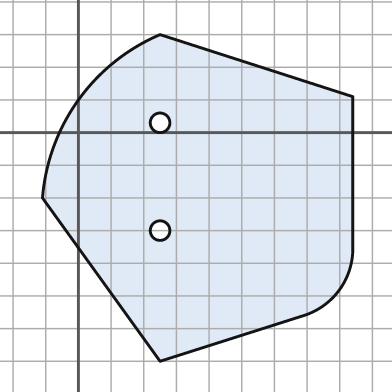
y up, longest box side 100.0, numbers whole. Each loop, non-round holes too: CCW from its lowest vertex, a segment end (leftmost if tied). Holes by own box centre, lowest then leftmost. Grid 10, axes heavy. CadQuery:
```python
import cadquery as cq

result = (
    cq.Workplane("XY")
    .moveTo(25.0, -70.0)
    .lineTo(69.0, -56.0)
    .threePointArc((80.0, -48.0), (84.0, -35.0))
    .lineTo(84.0, 11.0)
    .lineTo(25.0, 30.0)
    .threePointArc((0.0, 10.0), (-11.0, -20.0))
    .close()
    .moveTo(25.0, -30.0)
    .circle(3.0)
    .moveTo(25.0, 3.0)
    .circle(3.0)
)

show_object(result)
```